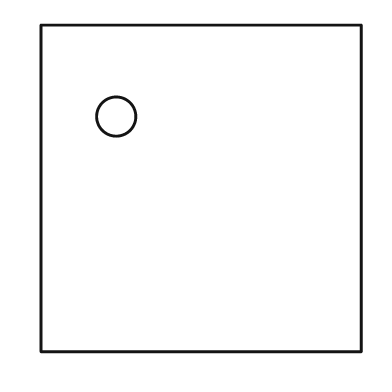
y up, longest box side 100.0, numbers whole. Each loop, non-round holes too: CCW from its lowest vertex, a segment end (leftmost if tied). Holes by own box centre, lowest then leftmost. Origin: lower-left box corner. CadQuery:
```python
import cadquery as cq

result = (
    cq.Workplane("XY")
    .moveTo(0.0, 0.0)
    .lineTo(98.0, 0.0)
    .lineTo(98.0, 100.0)
    .lineTo(0.0, 100.0)
    .close()
    .moveTo(23.0, 72.0)
    .circle(6.0)
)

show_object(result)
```